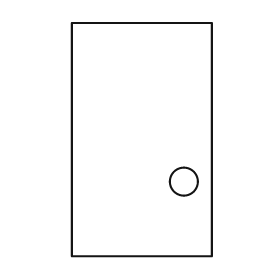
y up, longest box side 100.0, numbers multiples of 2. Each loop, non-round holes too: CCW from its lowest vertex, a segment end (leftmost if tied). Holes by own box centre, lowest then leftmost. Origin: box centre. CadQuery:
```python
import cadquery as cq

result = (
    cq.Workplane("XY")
    .moveTo(-30.0, -50.0)
    .lineTo(30.0, -50.0)
    .lineTo(30.0, 50.0)
    .lineTo(-30.0, 50.0)
    .close()
    .moveTo(18.0, -18.0)
    .circle(6.0)
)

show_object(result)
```